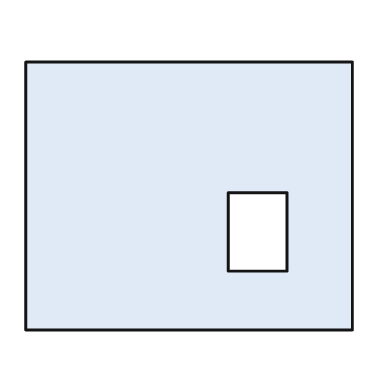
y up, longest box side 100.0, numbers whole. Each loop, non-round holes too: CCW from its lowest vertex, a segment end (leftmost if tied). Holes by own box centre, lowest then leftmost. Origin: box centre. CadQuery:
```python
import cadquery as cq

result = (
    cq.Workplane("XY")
    .moveTo(-50.0, -41.0)
    .lineTo(50.0, -41.0)
    .lineTo(50.0, 41.0)
    .lineTo(-50.0, 41.0)
    .close()
    .moveTo(12.0, -23.0)
    .lineTo(30.0, -23.0)
    .lineTo(30.0, 1.0)
    .lineTo(12.0, 1.0)
    .close()
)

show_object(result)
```